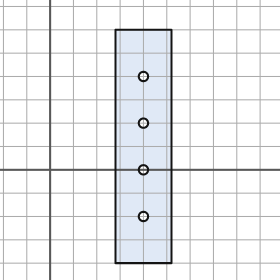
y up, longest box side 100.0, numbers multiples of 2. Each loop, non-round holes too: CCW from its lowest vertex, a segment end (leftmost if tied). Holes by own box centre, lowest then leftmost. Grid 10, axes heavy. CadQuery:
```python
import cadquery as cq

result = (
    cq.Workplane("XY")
    .moveTo(28.0, -40.0)
    .lineTo(52.0, -40.0)
    .lineTo(52.0, 60.0)
    .lineTo(28.0, 60.0)
    .close()
    .moveTo(40.0, -20.0)
    .circle(2.0)
    .moveTo(40.0, 0.0)
    .circle(2.0)
    .moveTo(40.0, 20.0)
    .circle(2.0)
    .moveTo(40.0, 40.0)
    .circle(2.0)
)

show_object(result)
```